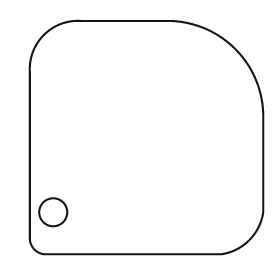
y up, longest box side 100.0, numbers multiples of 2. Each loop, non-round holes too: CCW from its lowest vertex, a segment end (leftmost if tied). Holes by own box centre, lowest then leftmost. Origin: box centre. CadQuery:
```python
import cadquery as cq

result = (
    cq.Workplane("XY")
    .moveTo(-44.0, -50.0)
    .lineTo(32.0, -50.0)
    .threePointArc((44.0, -44.0), (50.0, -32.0))
    .lineTo(50.0, 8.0)
    .threePointArc((38.0, 38.0), (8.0, 50.0))
    .lineTo(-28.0, 50.0)
    .threePointArc((-44.0, 44.0), (-50.0, 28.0))
    .lineTo(-50.0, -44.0)
    .threePointArc((-48.0, -48.0), (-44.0, -50.0))
    .close()
    .moveTo(-40.0, -32.0)
    .circle(6.0)
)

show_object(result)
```